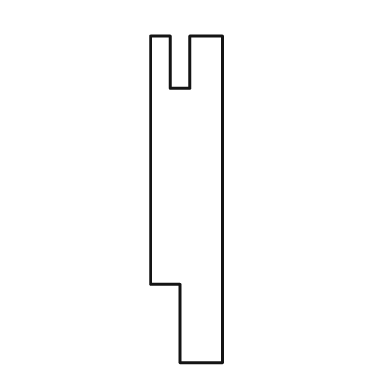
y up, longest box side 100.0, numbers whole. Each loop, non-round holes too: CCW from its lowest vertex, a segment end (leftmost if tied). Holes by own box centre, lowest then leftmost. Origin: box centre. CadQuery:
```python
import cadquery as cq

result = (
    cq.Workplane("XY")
    .moveTo(-2.0, -50.0)
    .lineTo(11.0, -50.0)
    .lineTo(11.0, 50.0)
    .lineTo(1.0, 50.0)
    .lineTo(1.0, 34.0)
    .lineTo(-5.0, 34.0)
    .lineTo(-5.0, 50.0)
    .lineTo(-11.0, 50.0)
    .lineTo(-11.0, -26.0)
    .lineTo(-2.0, -26.0)
    .close()
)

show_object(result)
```